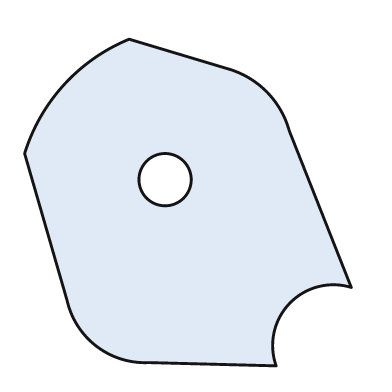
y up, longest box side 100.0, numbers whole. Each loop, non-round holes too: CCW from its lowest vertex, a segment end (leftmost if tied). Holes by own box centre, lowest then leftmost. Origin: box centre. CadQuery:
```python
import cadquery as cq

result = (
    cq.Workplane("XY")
    .moveTo(27.0, -50.0)
    .threePointArc((31.0, -31.0), (50.0, -26.0))
    .lineTo(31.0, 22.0)
    .threePointArc((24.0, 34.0), (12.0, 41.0))
    .lineTo(-18.0, 50.0)
    .threePointArc((-38.0, 36.0), (-50.0, 15.0))
    .lineTo(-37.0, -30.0)
    .threePointArc((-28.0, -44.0), (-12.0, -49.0))
    .close()
    .moveTo(-7.0, 7.0)
    .circle(8.0)
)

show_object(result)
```